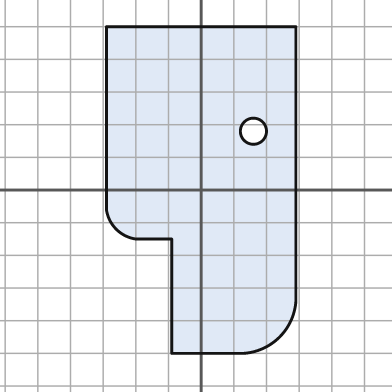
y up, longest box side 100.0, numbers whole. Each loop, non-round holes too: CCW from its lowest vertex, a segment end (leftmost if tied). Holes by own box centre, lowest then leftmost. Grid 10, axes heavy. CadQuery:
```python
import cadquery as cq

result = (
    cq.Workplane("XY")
    .moveTo(-9.0, -50.0)
    .lineTo(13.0, -50.0)
    .threePointArc((24.0, -45.0), (29.0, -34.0))
    .lineTo(29.0, 50.0)
    .lineTo(-29.0, 50.0)
    .lineTo(-29.0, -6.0)
    .threePointArc((-26.0, -12.0), (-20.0, -15.0))
    .lineTo(-9.0, -15.0)
    .close()
    .moveTo(16.0, 18.0)
    .circle(4.0)
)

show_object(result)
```